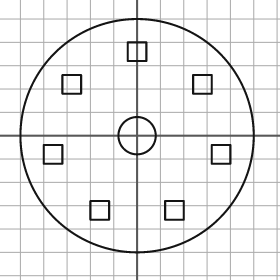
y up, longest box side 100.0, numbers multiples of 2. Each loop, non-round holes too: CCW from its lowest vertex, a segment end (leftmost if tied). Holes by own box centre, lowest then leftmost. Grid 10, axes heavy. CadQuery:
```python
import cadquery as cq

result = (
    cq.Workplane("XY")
    .moveTo(0.0, 0.0)
    .circle(50.0)
    .moveTo(-20.0, -36.0)
    .lineTo(-12.0, -36.0)
    .lineTo(-12.0, -28.0)
    .lineTo(-20.0, -28.0)
    .close()
    .moveTo(12.0, -36.0)
    .lineTo(20.0, -36.0)
    .lineTo(20.0, -28.0)
    .lineTo(12.0, -28.0)
    .close()
    .moveTo(-40.0, -12.0)
    .lineTo(-32.0, -12.0)
    .lineTo(-32.0, -4.0)
    .lineTo(-40.0, -4.0)
    .close()
    .moveTo(32.0, -12.0)
    .lineTo(40.0, -12.0)
    .lineTo(40.0, -4.0)
    .lineTo(32.0, -4.0)
    .close()
    .moveTo(0.0, 0.0)
    .circle(8.0)
    .moveTo(-32.0, 18.0)
    .lineTo(-24.0, 18.0)
    .lineTo(-24.0, 26.0)
    .lineTo(-32.0, 26.0)
    .close()
    .moveTo(24.0, 18.0)
    .lineTo(32.0, 18.0)
    .lineTo(32.0, 26.0)
    .lineTo(24.0, 26.0)
    .close()
    .moveTo(-4.0, 32.0)
    .lineTo(4.0, 32.0)
    .lineTo(4.0, 40.0)
    .lineTo(-4.0, 40.0)
    .close()
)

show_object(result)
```